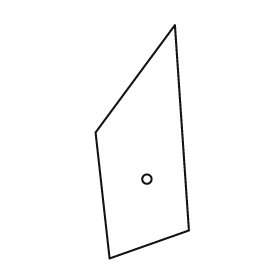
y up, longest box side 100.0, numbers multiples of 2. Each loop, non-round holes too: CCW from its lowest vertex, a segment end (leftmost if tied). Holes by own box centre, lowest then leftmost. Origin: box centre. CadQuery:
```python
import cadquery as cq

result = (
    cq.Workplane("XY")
    .moveTo(-14.0, -50.0)
    .lineTo(20.0, -38.0)
    .lineTo(14.0, 50.0)
    .lineTo(-20.0, 4.0)
    .close()
    .moveTo(2.0, -16.0)
    .circle(2.0)
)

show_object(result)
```